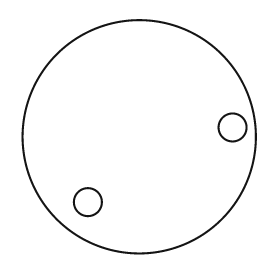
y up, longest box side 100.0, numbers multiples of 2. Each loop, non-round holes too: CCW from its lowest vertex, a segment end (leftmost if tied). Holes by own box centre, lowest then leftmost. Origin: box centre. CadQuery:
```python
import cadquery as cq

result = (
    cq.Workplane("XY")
    .moveTo(0.0, 0.0)
    .circle(50.0)
    .moveTo(-22.0, -28.0)
    .circle(6.0)
    .moveTo(40.0, 4.0)
    .circle(6.0)
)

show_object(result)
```